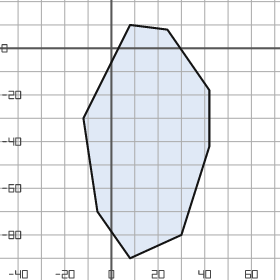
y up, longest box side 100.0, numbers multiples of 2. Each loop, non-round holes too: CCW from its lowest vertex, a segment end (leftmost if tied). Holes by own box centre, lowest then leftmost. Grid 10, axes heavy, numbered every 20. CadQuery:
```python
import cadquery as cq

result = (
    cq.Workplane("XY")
    .moveTo(8.0, -90.0)
    .lineTo(30.0, -80.0)
    .lineTo(42.0, -42.0)
    .lineTo(42.0, -18.0)
    .lineTo(24.0, 8.0)
    .lineTo(8.0, 10.0)
    .lineTo(-12.0, -30.0)
    .lineTo(-6.0, -70.0)
    .close()
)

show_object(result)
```